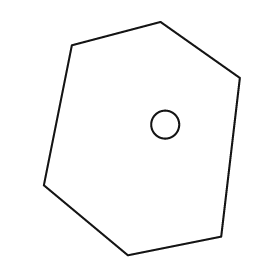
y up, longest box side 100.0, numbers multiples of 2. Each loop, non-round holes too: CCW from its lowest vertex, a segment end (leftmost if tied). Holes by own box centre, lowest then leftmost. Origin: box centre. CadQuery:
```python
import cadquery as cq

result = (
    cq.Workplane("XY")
    .moveTo(-6.0, -50.0)
    .lineTo(34.0, -42.0)
    .lineTo(42.0, 26.0)
    .lineTo(8.0, 50.0)
    .lineTo(-30.0, 40.0)
    .lineTo(-42.0, -20.0)
    .close()
    .moveTo(10.0, 6.0)
    .circle(6.0)
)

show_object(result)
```